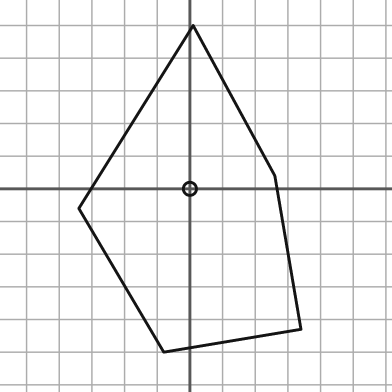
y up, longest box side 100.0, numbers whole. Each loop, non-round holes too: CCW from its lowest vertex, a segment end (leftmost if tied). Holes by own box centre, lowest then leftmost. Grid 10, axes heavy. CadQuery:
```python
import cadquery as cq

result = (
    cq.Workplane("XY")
    .moveTo(-8.0, -50.0)
    .lineTo(34.0, -43.0)
    .lineTo(26.0, 4.0)
    .lineTo(1.0, 50.0)
    .lineTo(-34.0, -6.0)
    .close()
    .moveTo(0.0, 0.0)
    .circle(2.0)
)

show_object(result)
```